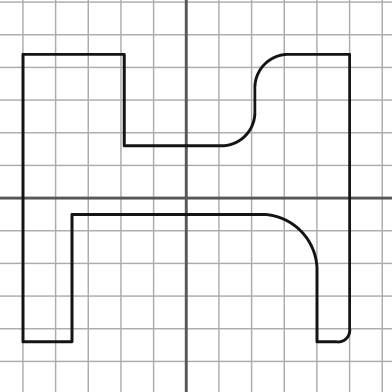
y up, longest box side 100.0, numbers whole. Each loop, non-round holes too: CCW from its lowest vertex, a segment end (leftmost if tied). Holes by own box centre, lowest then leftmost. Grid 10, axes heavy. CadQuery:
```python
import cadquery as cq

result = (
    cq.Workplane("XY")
    .moveTo(-50.0, -44.0)
    .lineTo(-35.0, -44.0)
    .lineTo(-35.0, -5.0)
    .lineTo(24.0, -5.0)
    .threePointArc((35.0, -10.0), (40.0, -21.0))
    .lineTo(40.0, -44.0)
    .lineTo(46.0, -44.0)
    .threePointArc((49.0, -43.0), (50.0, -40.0))
    .lineTo(50.0, 44.0)
    .lineTo(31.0, 44.0)
    .threePointArc((24.0, 41.0), (21.0, 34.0))
    .lineTo(21.0, 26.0)
    .threePointArc((18.0, 19.0), (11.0, 16.0))
    .lineTo(-19.0, 16.0)
    .lineTo(-19.0, 44.0)
    .lineTo(-50.0, 44.0)
    .close()
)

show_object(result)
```